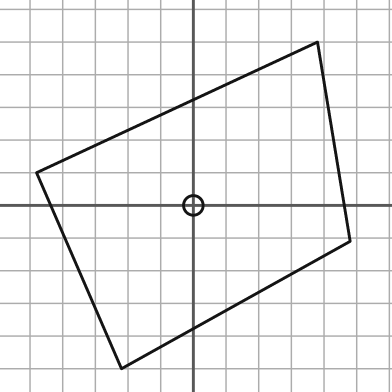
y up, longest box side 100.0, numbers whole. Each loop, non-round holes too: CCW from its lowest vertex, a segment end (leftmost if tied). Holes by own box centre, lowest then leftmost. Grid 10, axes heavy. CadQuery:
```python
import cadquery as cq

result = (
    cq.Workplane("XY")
    .moveTo(-22.0, -50.0)
    .lineTo(48.0, -11.0)
    .lineTo(38.0, 50.0)
    .lineTo(-48.0, 10.0)
    .close()
    .moveTo(0.0, 0.0)
    .circle(3.0)
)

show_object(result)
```